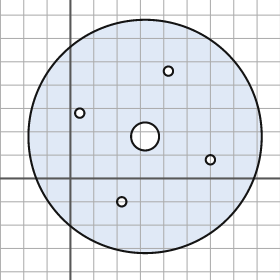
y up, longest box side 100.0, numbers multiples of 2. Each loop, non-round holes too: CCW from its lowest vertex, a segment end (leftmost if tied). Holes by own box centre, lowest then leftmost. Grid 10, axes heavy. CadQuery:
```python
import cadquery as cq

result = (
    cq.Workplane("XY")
    .moveTo(32.0, 18.0)
    .circle(50.0)
    .moveTo(22.0, -10.0)
    .circle(2.0)
    .moveTo(60.0, 8.0)
    .circle(2.0)
    .moveTo(32.0, 18.0)
    .circle(6.0)
    .moveTo(4.0, 28.0)
    .circle(2.0)
    .moveTo(42.0, 46.0)
    .circle(2.0)
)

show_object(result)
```